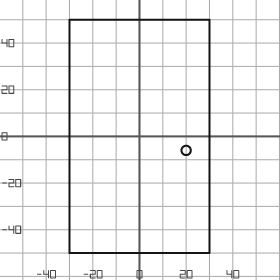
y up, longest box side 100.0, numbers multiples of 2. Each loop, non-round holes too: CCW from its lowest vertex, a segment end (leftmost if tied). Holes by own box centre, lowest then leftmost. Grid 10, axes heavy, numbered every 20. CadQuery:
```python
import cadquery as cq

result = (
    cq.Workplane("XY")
    .moveTo(-30.0, -50.0)
    .lineTo(30.0, -50.0)
    .lineTo(30.0, 50.0)
    .lineTo(-30.0, 50.0)
    .close()
    .moveTo(20.0, -6.0)
    .circle(2.0)
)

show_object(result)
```